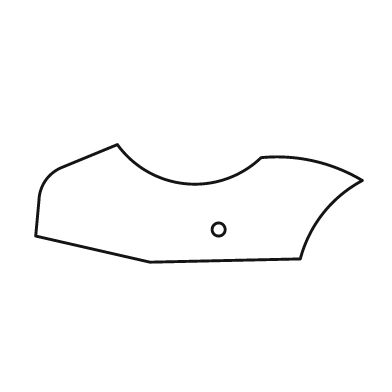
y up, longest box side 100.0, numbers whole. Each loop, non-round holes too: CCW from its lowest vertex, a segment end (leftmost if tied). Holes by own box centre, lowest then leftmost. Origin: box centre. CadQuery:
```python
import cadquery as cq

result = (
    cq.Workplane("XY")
    .moveTo(-15.0, -18.0)
    .lineTo(31.0, -17.0)
    .threePointArc((38.0, -3.0), (50.0, 7.0))
    .threePointArc((35.0, 13.0), (19.0, 14.0))
    .threePointArc((-4.0, 6.0), (-25.0, 18.0))
    .lineTo(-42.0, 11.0)
    .threePointArc((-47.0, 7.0), (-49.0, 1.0))
    .lineTo(-50.0, -10.0)
    .close()
    .moveTo(6.0, -8.0)
    .circle(2.0)
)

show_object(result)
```